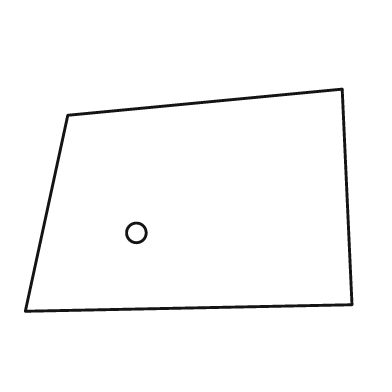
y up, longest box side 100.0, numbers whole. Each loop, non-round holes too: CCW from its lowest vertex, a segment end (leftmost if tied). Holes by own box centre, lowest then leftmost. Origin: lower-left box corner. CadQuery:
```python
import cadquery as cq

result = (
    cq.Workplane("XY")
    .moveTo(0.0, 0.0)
    .lineTo(100.0, 2.0)
    .lineTo(97.0, 68.0)
    .lineTo(13.0, 60.0)
    .close()
    .moveTo(34.0, 24.0)
    .circle(3.0)
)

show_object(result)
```